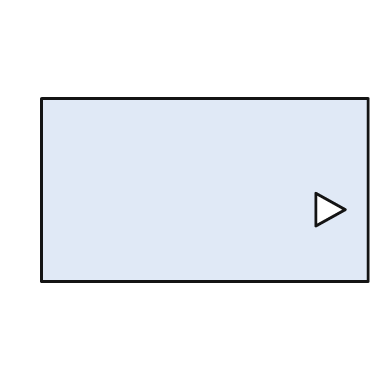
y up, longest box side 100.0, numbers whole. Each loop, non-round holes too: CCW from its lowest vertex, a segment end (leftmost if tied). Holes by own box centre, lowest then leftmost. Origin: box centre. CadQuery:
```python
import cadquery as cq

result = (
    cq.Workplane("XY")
    .moveTo(-50.0, -28.0)
    .lineTo(50.0, -28.0)
    .lineTo(50.0, 28.0)
    .lineTo(-50.0, 28.0)
    .close()
    .moveTo(34.0, -11.0)
    .lineTo(43.0, -6.0)
    .lineTo(34.0, -1.0)
    .close()
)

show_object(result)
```